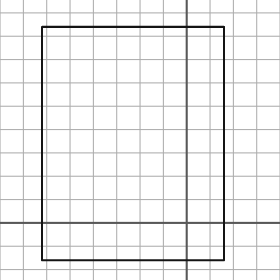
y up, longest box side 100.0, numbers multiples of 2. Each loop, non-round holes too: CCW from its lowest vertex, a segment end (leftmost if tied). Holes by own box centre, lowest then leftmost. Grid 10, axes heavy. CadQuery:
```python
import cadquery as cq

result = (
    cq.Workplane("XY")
    .moveTo(-62.0, -16.0)
    .lineTo(16.0, -16.0)
    .lineTo(16.0, 84.0)
    .lineTo(-62.0, 84.0)
    .close()
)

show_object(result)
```